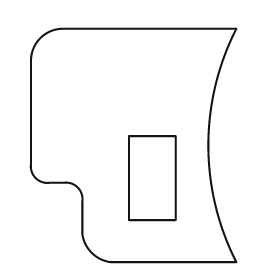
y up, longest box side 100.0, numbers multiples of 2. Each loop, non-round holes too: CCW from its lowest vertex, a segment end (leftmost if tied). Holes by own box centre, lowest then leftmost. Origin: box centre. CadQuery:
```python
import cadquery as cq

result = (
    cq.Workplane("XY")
    .moveTo(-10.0, -50.0)
    .lineTo(44.0, -50.0)
    .threePointArc((32.0, 0.0), (44.0, 50.0))
    .lineTo(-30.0, 50.0)
    .threePointArc((-40.0, 46.0), (-44.0, 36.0))
    .lineTo(-44.0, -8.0)
    .threePointArc((-42.0, -14.0), (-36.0, -16.0))
    .lineTo(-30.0, -16.0)
    .threePointArc((-24.0, -18.0), (-22.0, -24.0))
    .lineTo(-22.0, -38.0)
    .threePointArc((-18.0, -46.0), (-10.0, -50.0))
    .close()
    .moveTo(-2.0, -32.0)
    .lineTo(18.0, -32.0)
    .lineTo(18.0, 4.0)
    .lineTo(-2.0, 4.0)
    .close()
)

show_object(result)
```